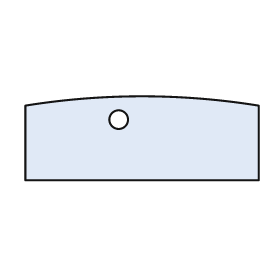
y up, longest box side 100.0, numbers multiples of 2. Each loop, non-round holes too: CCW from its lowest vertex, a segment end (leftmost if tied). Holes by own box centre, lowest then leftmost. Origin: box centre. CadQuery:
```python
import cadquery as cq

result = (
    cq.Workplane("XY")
    .moveTo(-50.0, -18.0)
    .lineTo(50.0, -18.0)
    .lineTo(50.0, 14.0)
    .threePointArc((0.0, 18.0), (-50.0, 14.0))
    .close()
    .moveTo(-10.0, 8.0)
    .circle(4.0)
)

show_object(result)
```